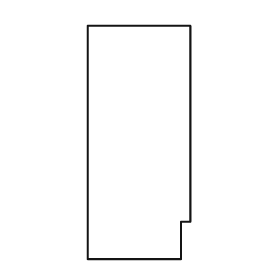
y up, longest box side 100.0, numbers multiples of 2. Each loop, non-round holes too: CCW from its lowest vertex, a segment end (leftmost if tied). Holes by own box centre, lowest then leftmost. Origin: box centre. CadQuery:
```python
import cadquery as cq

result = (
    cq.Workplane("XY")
    .moveTo(-22.0, -50.0)
    .lineTo(18.0, -50.0)
    .lineTo(18.0, -34.0)
    .lineTo(22.0, -34.0)
    .lineTo(22.0, 50.0)
    .lineTo(-22.0, 50.0)
    .close()
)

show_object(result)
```